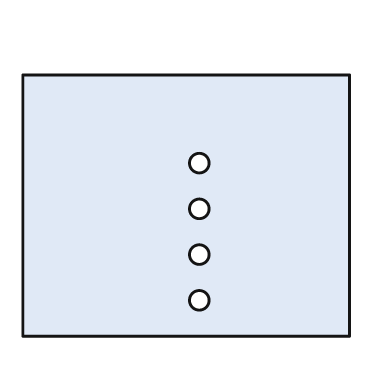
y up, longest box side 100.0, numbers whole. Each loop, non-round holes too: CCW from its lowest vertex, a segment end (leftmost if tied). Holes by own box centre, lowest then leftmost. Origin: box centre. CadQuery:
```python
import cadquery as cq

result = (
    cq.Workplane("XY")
    .moveTo(-50.0, -40.0)
    .lineTo(50.0, -40.0)
    .lineTo(50.0, 40.0)
    .lineTo(-50.0, 40.0)
    .close()
    .moveTo(4.0, -29.0)
    .circle(3.0)
    .moveTo(4.0, -15.0)
    .circle(3.0)
    .moveTo(4.0, -1.0)
    .circle(3.0)
    .moveTo(4.0, 13.0)
    .circle(3.0)
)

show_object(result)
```